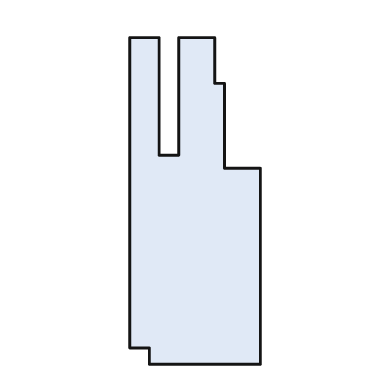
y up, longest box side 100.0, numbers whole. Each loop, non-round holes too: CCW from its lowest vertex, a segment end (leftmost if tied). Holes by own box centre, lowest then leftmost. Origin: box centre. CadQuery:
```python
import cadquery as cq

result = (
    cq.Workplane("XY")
    .moveTo(-14.0, -50.0)
    .lineTo(20.0, -50.0)
    .lineTo(20.0, 10.0)
    .lineTo(9.0, 10.0)
    .lineTo(9.0, 36.0)
    .lineTo(6.0, 36.0)
    .lineTo(6.0, 50.0)
    .lineTo(-5.0, 50.0)
    .lineTo(-5.0, 14.0)
    .lineTo(-11.0, 14.0)
    .lineTo(-11.0, 50.0)
    .lineTo(-20.0, 50.0)
    .lineTo(-20.0, -45.0)
    .lineTo(-14.0, -45.0)
    .close()
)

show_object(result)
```